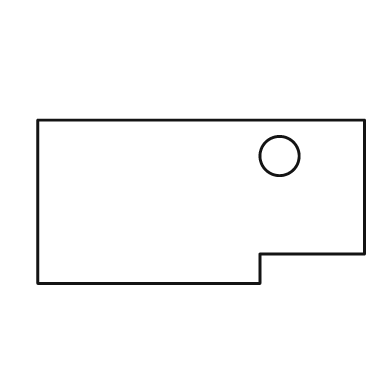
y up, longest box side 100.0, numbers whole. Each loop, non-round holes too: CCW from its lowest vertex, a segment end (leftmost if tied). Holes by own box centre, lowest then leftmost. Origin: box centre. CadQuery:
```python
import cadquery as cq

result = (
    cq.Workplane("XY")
    .moveTo(-50.0, -25.0)
    .lineTo(18.0, -25.0)
    .lineTo(18.0, -16.0)
    .lineTo(50.0, -16.0)
    .lineTo(50.0, 25.0)
    .lineTo(-50.0, 25.0)
    .close()
    .moveTo(24.0, 14.0)
    .circle(6.0)
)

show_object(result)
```